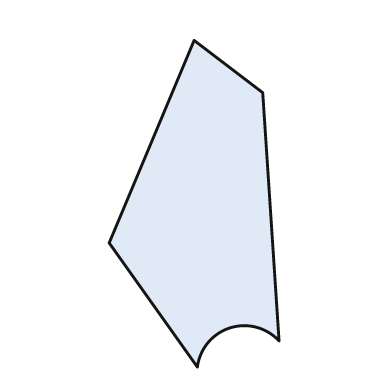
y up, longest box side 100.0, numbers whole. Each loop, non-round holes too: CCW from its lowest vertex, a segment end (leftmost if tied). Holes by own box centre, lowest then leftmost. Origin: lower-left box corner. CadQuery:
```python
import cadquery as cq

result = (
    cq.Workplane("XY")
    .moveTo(27.0, 0.0)
    .threePointArc((37.0, 12.0), (52.0, 8.0))
    .lineTo(47.0, 84.0)
    .lineTo(26.0, 100.0)
    .lineTo(0.0, 38.0)
    .close()
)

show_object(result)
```